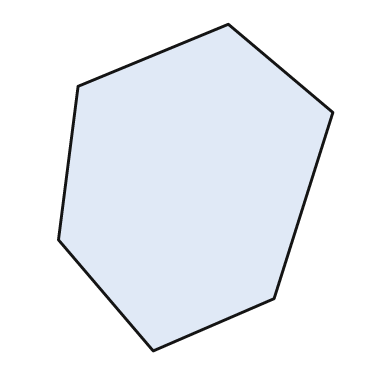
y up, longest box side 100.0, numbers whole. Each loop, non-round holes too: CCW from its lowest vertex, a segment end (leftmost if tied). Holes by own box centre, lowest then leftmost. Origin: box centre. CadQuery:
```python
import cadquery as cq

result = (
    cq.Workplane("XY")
    .moveTo(-13.0, -50.0)
    .lineTo(24.0, -34.0)
    .lineTo(42.0, 23.0)
    .lineTo(10.0, 50.0)
    .lineTo(-36.0, 31.0)
    .lineTo(-42.0, -16.0)
    .close()
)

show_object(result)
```